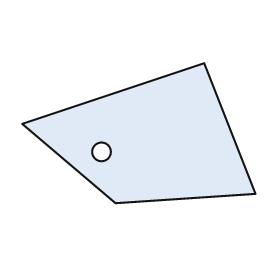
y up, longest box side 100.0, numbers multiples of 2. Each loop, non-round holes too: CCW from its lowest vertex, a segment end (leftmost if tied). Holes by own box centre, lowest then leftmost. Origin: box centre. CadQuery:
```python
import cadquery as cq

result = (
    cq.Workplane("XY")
    .moveTo(-10.0, -30.0)
    .lineTo(50.0, -26.0)
    .lineTo(28.0, 30.0)
    .lineTo(-50.0, 4.0)
    .close()
    .moveTo(-16.0, -8.0)
    .circle(4.0)
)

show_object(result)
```